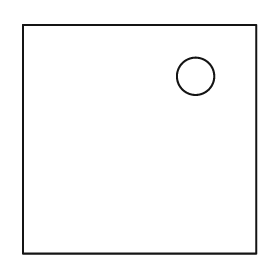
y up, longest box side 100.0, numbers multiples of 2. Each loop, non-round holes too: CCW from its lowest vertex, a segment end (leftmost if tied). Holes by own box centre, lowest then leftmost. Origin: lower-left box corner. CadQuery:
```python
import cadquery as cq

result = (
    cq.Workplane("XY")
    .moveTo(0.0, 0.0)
    .lineTo(100.0, 0.0)
    .lineTo(100.0, 98.0)
    .lineTo(0.0, 98.0)
    .close()
    .moveTo(74.0, 76.0)
    .circle(8.0)
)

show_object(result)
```